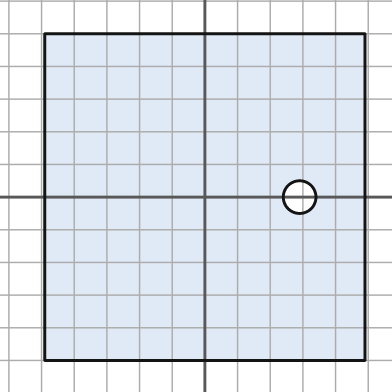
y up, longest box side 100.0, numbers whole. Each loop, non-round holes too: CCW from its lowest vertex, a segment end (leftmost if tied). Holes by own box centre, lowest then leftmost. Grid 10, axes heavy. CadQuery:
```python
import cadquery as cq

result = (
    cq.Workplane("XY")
    .moveTo(-49.0, -50.0)
    .lineTo(49.0, -50.0)
    .lineTo(49.0, 50.0)
    .lineTo(-49.0, 50.0)
    .close()
    .moveTo(29.0, 0.0)
    .circle(5.0)
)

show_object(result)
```